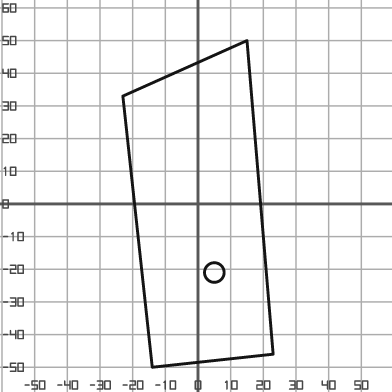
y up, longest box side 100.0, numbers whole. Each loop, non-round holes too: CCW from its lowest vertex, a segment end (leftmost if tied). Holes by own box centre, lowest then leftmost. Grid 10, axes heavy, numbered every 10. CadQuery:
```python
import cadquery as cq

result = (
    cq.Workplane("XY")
    .moveTo(-14.0, -50.0)
    .lineTo(23.0, -46.0)
    .lineTo(15.0, 50.0)
    .lineTo(-23.0, 33.0)
    .close()
    .moveTo(5.0, -21.0)
    .circle(3.0)
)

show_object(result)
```